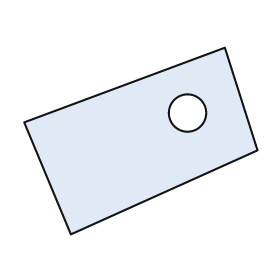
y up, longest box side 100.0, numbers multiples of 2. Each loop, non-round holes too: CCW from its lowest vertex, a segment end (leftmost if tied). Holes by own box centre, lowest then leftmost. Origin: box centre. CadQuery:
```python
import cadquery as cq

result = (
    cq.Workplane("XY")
    .moveTo(-30.0, -40.0)
    .lineTo(50.0, -4.0)
    .lineTo(36.0, 40.0)
    .lineTo(-50.0, 8.0)
    .close()
    .moveTo(20.0, 12.0)
    .circle(8.0)
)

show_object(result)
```